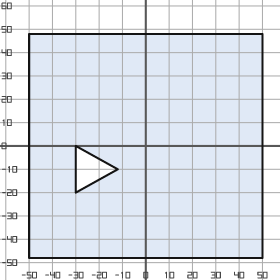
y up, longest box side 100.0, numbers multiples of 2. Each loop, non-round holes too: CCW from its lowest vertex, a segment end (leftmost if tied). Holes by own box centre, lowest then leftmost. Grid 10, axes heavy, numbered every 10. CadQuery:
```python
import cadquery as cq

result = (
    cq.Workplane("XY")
    .moveTo(-50.0, -48.0)
    .lineTo(50.0, -48.0)
    .lineTo(50.0, 48.0)
    .lineTo(-50.0, 48.0)
    .close()
    .moveTo(-30.0, -20.0)
    .lineTo(-12.0, -10.0)
    .lineTo(-30.0, 0.0)
    .close()
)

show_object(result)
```